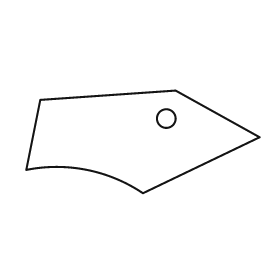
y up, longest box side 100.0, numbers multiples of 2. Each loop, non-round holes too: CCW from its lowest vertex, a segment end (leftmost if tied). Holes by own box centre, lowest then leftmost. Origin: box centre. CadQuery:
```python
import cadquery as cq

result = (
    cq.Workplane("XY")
    .moveTo(0.0, -22.0)
    .lineTo(50.0, 2.0)
    .lineTo(14.0, 22.0)
    .lineTo(-44.0, 18.0)
    .lineTo(-50.0, -12.0)
    .threePointArc((-24.0, -12.0), (0.0, -22.0))
    .close()
    .moveTo(10.0, 10.0)
    .circle(4.0)
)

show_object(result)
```